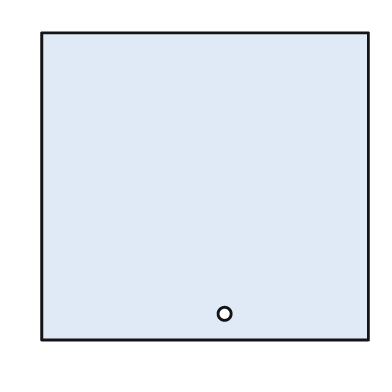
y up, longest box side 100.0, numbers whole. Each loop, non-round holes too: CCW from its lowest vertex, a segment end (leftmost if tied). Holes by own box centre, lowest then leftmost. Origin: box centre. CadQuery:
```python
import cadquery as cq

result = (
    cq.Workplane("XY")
    .moveTo(-50.0, -47.0)
    .lineTo(50.0, -47.0)
    .lineTo(50.0, 47.0)
    .lineTo(-50.0, 47.0)
    .close()
    .moveTo(6.0, -39.0)
    .circle(2.0)
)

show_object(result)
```